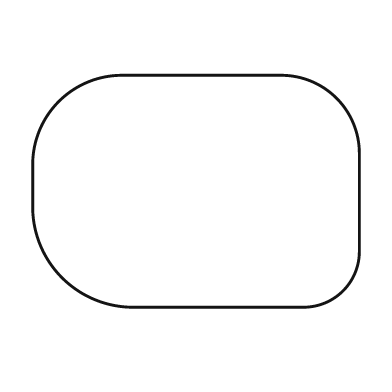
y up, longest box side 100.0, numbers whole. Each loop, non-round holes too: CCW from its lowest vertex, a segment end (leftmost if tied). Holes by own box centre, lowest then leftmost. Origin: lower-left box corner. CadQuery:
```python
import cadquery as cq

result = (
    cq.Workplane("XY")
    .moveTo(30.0, 0.0)
    .lineTo(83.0, 0.0)
    .threePointArc((95.0, 5.0), (100.0, 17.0))
    .lineTo(100.0, 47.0)
    .threePointArc((93.0, 64.0), (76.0, 71.0))
    .lineTo(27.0, 71.0)
    .threePointArc((8.0, 63.0), (0.0, 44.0))
    .lineTo(0.0, 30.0)
    .threePointArc((9.0, 9.0), (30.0, 0.0))
    .close()
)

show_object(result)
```